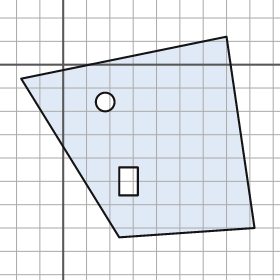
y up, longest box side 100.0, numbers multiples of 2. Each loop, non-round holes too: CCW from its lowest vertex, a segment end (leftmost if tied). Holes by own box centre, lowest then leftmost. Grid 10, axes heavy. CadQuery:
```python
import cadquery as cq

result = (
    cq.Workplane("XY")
    .moveTo(24.0, -74.0)
    .lineTo(82.0, -70.0)
    .lineTo(70.0, 12.0)
    .lineTo(-18.0, -6.0)
    .close()
    .moveTo(24.0, -56.0)
    .lineTo(32.0, -56.0)
    .lineTo(32.0, -44.0)
    .lineTo(24.0, -44.0)
    .close()
    .moveTo(18.0, -16.0)
    .circle(4.0)
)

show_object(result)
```